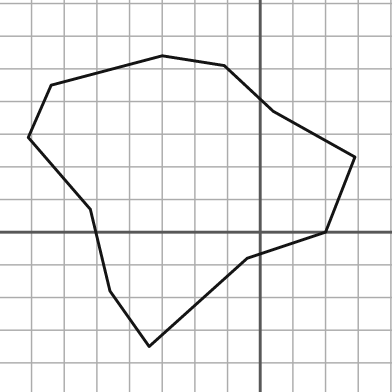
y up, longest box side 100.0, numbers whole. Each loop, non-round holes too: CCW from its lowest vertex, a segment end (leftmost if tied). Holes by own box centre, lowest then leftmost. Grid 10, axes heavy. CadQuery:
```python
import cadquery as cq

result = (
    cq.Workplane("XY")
    .moveTo(-34.0, -35.0)
    .lineTo(-4.0, -8.0)
    .lineTo(20.0, 0.0)
    .lineTo(29.0, 23.0)
    .lineTo(4.0, 37.0)
    .lineTo(-11.0, 51.0)
    .lineTo(-30.0, 54.0)
    .lineTo(-64.0, 45.0)
    .lineTo(-71.0, 29.0)
    .lineTo(-52.0, 7.0)
    .lineTo(-46.0, -18.0)
    .close()
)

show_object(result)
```